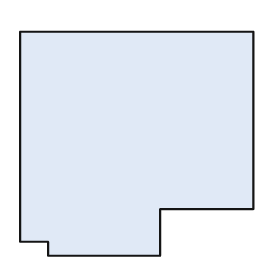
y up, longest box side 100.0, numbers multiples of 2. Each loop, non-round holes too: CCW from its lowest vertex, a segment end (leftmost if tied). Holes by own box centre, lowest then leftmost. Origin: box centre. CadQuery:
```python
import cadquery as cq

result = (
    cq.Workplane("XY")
    .moveTo(-38.0, -48.0)
    .lineTo(10.0, -48.0)
    .lineTo(10.0, -28.0)
    .lineTo(50.0, -28.0)
    .lineTo(50.0, 48.0)
    .lineTo(-50.0, 48.0)
    .lineTo(-50.0, -42.0)
    .lineTo(-38.0, -42.0)
    .close()
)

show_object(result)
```